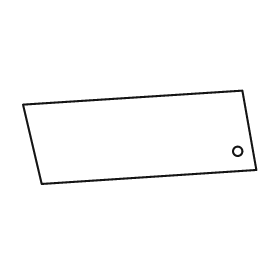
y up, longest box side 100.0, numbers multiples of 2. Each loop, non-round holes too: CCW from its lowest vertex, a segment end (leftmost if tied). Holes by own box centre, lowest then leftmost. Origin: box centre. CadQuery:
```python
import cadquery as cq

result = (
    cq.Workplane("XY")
    .moveTo(-42.0, -20.0)
    .lineTo(50.0, -14.0)
    .lineTo(44.0, 20.0)
    .lineTo(-50.0, 14.0)
    .close()
    .moveTo(42.0, -6.0)
    .circle(2.0)
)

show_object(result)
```